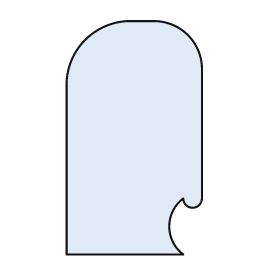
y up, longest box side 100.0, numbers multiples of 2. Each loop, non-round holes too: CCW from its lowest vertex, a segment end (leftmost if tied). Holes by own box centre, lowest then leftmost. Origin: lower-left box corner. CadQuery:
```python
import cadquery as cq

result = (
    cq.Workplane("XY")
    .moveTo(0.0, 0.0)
    .lineTo(50.0, 0.0)
    .threePointArc((44.0, 12.0), (50.0, 24.0))
    .threePointArc((54.0, 20.0), (58.0, 24.0))
    .lineTo(58.0, 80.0)
    .threePointArc((52.0, 94.0), (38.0, 100.0))
    .lineTo(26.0, 100.0)
    .threePointArc((8.0, 92.0), (0.0, 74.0))
    .close()
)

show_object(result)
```